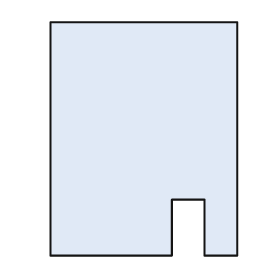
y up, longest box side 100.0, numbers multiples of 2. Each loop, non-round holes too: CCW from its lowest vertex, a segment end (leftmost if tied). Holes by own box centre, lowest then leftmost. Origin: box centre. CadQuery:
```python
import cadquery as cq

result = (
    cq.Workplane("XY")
    .moveTo(-40.0, -50.0)
    .lineTo(12.0, -50.0)
    .lineTo(12.0, -26.0)
    .lineTo(26.0, -26.0)
    .lineTo(26.0, -50.0)
    .lineTo(40.0, -50.0)
    .lineTo(40.0, 50.0)
    .lineTo(-40.0, 50.0)
    .close()
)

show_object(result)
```